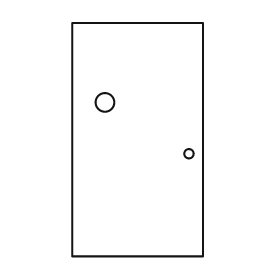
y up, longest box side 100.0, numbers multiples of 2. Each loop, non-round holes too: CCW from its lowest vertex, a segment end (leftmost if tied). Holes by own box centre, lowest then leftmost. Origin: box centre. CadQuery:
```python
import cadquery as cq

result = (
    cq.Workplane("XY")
    .moveTo(-28.0, -50.0)
    .lineTo(28.0, -50.0)
    .lineTo(28.0, 50.0)
    .lineTo(-28.0, 50.0)
    .close()
    .moveTo(22.0, -6.0)
    .circle(2.0)
    .moveTo(-14.0, 16.0)
    .circle(4.0)
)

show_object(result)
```